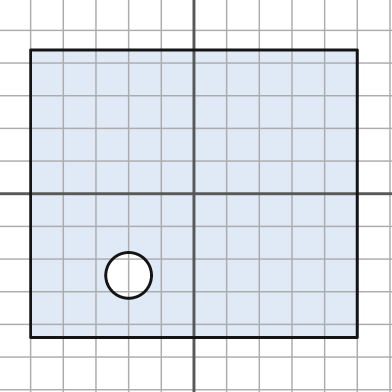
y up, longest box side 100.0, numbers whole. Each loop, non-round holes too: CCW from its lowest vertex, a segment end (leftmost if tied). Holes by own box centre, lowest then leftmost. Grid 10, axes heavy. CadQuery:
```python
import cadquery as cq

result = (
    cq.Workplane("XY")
    .moveTo(-50.0, -44.0)
    .lineTo(50.0, -44.0)
    .lineTo(50.0, 44.0)
    .lineTo(-50.0, 44.0)
    .close()
    .moveTo(-20.0, -25.0)
    .circle(7.0)
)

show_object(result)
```